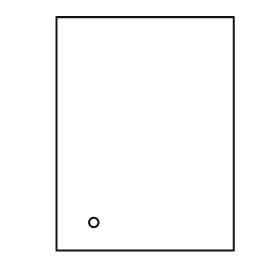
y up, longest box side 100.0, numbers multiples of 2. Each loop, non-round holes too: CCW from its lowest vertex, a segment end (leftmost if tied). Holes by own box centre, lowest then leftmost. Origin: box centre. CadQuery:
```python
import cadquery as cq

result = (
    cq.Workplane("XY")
    .moveTo(-38.0, -50.0)
    .lineTo(38.0, -50.0)
    .lineTo(38.0, 50.0)
    .lineTo(-38.0, 50.0)
    .close()
    .moveTo(-22.0, -38.0)
    .circle(2.0)
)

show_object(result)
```